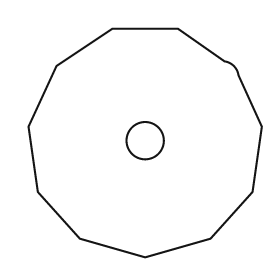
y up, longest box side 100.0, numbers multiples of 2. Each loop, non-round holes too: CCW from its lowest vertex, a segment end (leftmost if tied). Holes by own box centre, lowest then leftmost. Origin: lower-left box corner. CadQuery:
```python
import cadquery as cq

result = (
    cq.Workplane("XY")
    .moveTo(50.0, 0.0)
    .lineTo(78.0, 8.0)
    .lineTo(96.0, 28.0)
    .lineTo(100.0, 56.0)
    .lineTo(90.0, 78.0)
    .threePointArc((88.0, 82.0), (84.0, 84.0))
    .lineTo(64.0, 98.0)
    .lineTo(36.0, 98.0)
    .lineTo(12.0, 82.0)
    .lineTo(0.0, 56.0)
    .lineTo(4.0, 28.0)
    .lineTo(22.0, 8.0)
    .close()
    .moveTo(50.0, 50.0)
    .circle(8.0)
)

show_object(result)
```